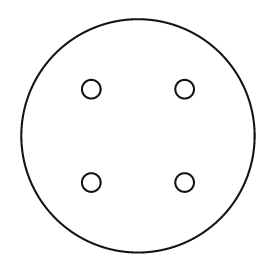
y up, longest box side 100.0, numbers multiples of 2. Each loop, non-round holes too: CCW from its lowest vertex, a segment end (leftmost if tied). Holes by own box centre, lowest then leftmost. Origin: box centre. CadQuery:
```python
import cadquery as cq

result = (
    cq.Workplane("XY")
    .moveTo(0.0, 0.0)
    .circle(50.0)
    .moveTo(-20.0, -20.0)
    .circle(4.0)
    .moveTo(20.0, -20.0)
    .circle(4.0)
    .moveTo(-20.0, 20.0)
    .circle(4.0)
    .moveTo(20.0, 20.0)
    .circle(4.0)
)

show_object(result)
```